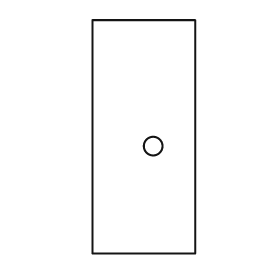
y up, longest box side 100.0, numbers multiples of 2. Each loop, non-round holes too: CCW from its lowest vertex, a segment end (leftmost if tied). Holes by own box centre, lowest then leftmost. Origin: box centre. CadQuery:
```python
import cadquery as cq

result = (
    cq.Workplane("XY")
    .moveTo(-22.0, -50.0)
    .lineTo(22.0, -50.0)
    .lineTo(22.0, 50.0)
    .lineTo(-22.0, 50.0)
    .close()
    .moveTo(4.0, -4.0)
    .circle(4.0)
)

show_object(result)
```